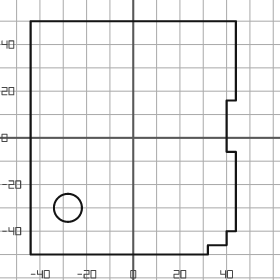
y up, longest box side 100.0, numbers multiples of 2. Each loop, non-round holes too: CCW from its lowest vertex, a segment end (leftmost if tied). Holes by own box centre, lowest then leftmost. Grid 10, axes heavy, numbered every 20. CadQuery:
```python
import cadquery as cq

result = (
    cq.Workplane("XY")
    .moveTo(-44.0, -50.0)
    .lineTo(32.0, -50.0)
    .lineTo(32.0, -46.0)
    .lineTo(40.0, -46.0)
    .lineTo(40.0, -40.0)
    .lineTo(44.0, -40.0)
    .lineTo(44.0, -6.0)
    .lineTo(40.0, -6.0)
    .lineTo(40.0, 16.0)
    .lineTo(44.0, 16.0)
    .lineTo(44.0, 50.0)
    .lineTo(-44.0, 50.0)
    .close()
    .moveTo(-28.0, -30.0)
    .circle(6.0)
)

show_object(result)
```